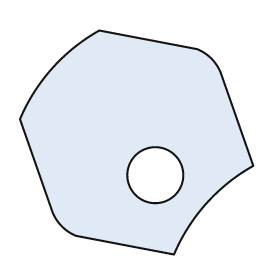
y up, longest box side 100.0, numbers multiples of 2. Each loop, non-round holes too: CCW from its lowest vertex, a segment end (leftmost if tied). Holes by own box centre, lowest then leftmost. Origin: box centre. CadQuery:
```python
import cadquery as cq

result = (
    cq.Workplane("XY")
    .moveTo(16.0, -48.0)
    .threePointArc((30.0, -26.0), (50.0, -10.0))
    .lineTo(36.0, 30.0)
    .threePointArc((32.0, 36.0), (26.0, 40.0))
    .lineTo(-16.0, 48.0)
    .threePointArc((-36.0, 32.0), (-50.0, 10.0))
    .lineTo(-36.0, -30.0)
    .threePointArc((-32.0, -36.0), (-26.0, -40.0))
    .close()
    .moveTo(8.0, -14.0)
    .circle(12.0)
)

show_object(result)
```